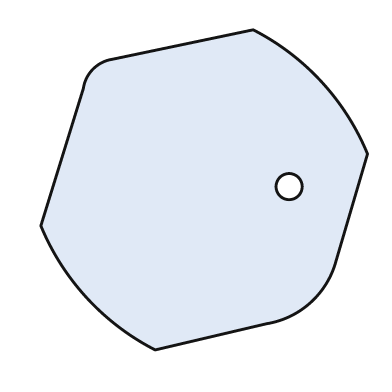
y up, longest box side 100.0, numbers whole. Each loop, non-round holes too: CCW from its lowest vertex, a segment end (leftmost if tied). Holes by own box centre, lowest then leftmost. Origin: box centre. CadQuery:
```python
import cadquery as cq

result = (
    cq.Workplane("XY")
    .moveTo(-15.0, -49.0)
    .lineTo(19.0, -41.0)
    .threePointArc((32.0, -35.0), (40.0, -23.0))
    .lineTo(50.0, 11.0)
    .threePointArc((36.0, 33.0), (15.0, 49.0))
    .lineTo(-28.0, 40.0)
    .threePointArc((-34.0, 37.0), (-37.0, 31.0))
    .lineTo(-50.0, -11.0)
    .threePointArc((-36.0, -33.0), (-15.0, -49.0))
    .close()
    .moveTo(26.0, 1.0)
    .circle(4.0)
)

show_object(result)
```